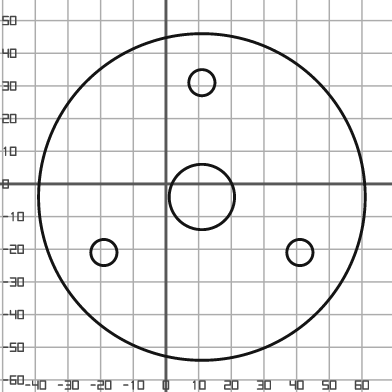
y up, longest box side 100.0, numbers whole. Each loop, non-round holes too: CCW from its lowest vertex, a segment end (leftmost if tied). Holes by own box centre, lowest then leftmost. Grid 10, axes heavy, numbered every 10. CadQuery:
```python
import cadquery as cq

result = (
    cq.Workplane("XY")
    .moveTo(11.0, -4.0)
    .circle(50.0)
    .moveTo(-19.0, -21.0)
    .circle(4.0)
    .moveTo(41.0, -21.0)
    .circle(4.0)
    .moveTo(11.0, -4.0)
    .circle(10.0)
    .moveTo(11.0, 31.0)
    .circle(4.0)
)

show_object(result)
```